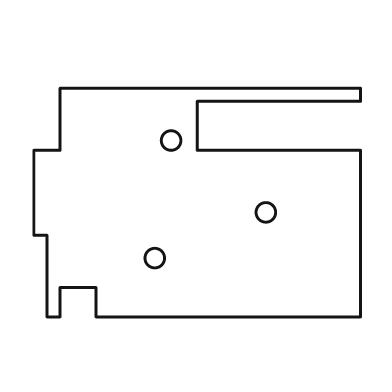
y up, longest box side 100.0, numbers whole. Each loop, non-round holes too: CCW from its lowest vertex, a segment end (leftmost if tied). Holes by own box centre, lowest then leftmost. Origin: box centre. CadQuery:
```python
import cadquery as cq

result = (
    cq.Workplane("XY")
    .moveTo(-46.0, -35.0)
    .lineTo(-42.0, -35.0)
    .lineTo(-42.0, -26.0)
    .lineTo(-31.0, -26.0)
    .lineTo(-31.0, -35.0)
    .lineTo(50.0, -35.0)
    .lineTo(50.0, 16.0)
    .lineTo(0.0, 16.0)
    .lineTo(0.0, 31.0)
    .lineTo(50.0, 31.0)
    .lineTo(50.0, 35.0)
    .lineTo(-42.0, 35.0)
    .lineTo(-42.0, 16.0)
    .lineTo(-50.0, 16.0)
    .lineTo(-50.0, -10.0)
    .lineTo(-46.0, -10.0)
    .close()
    .moveTo(-13.0, -17.0)
    .circle(3.0)
    .moveTo(21.0, -3.0)
    .circle(3.0)
    .moveTo(-8.0, 19.0)
    .circle(3.0)
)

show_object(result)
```